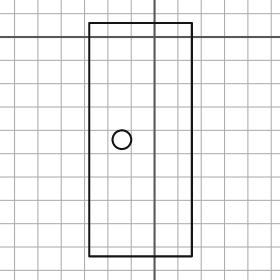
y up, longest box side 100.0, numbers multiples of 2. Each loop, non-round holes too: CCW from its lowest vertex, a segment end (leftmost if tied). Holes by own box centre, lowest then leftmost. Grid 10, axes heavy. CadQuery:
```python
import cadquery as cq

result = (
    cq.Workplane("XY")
    .moveTo(-28.0, -94.0)
    .lineTo(16.0, -94.0)
    .lineTo(16.0, 6.0)
    .lineTo(-28.0, 6.0)
    .close()
    .moveTo(-14.0, -44.0)
    .circle(4.0)
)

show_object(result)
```